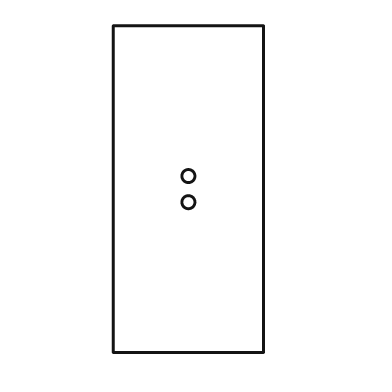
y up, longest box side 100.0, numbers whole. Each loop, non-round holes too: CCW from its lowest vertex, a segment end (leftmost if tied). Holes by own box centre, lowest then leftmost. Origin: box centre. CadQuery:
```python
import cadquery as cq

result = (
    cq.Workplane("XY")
    .moveTo(-23.0, -50.0)
    .lineTo(23.0, -50.0)
    .lineTo(23.0, 50.0)
    .lineTo(-23.0, 50.0)
    .close()
    .moveTo(0.0, -4.0)
    .circle(2.0)
    .moveTo(0.0, 4.0)
    .circle(2.0)
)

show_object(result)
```